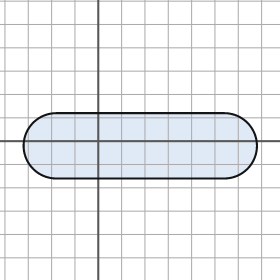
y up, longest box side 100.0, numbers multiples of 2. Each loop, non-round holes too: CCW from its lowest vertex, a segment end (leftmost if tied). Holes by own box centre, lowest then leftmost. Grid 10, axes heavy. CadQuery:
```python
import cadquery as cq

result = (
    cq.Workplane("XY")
    .moveTo(-18.0, -16.0)
    .lineTo(54.0, -16.0)
    .threePointArc((68.0, -2.0), (54.0, 12.0))
    .lineTo(-18.0, 12.0)
    .threePointArc((-32.0, -2.0), (-18.0, -16.0))
    .close()
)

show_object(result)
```